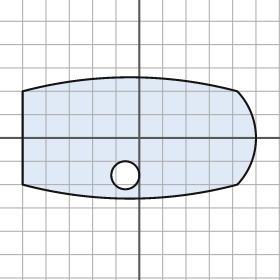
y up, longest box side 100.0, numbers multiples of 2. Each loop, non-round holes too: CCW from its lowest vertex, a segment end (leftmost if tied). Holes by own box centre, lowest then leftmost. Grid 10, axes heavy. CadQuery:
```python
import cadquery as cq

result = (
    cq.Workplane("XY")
    .moveTo(-50.0, -20.0)
    .threePointArc((-4.0, -26.0), (42.0, -20.0))
    .threePointArc((50.0, 0.0), (42.0, 20.0))
    .threePointArc((-4.0, 26.0), (-50.0, 20.0))
    .close()
    .moveTo(-6.0, -16.0)
    .circle(6.0)
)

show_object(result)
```